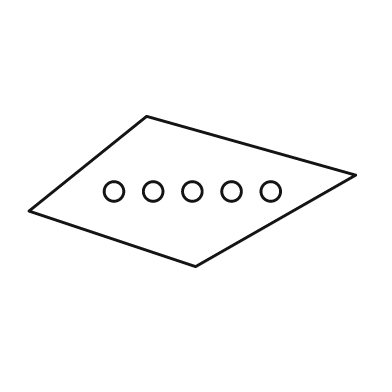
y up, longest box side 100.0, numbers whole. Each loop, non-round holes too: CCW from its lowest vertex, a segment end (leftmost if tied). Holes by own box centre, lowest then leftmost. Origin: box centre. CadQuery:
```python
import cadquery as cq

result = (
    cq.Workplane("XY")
    .moveTo(1.0, -23.0)
    .lineTo(50.0, 5.0)
    .lineTo(-14.0, 23.0)
    .lineTo(-50.0, -6.0)
    .close()
    .moveTo(-24.0, 0.0)
    .circle(3.0)
    .moveTo(-12.0, 0.0)
    .circle(3.0)
    .moveTo(0.0, 0.0)
    .circle(3.0)
    .moveTo(12.0, 0.0)
    .circle(3.0)
    .moveTo(24.0, 0.0)
    .circle(3.0)
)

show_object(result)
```